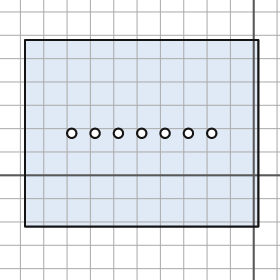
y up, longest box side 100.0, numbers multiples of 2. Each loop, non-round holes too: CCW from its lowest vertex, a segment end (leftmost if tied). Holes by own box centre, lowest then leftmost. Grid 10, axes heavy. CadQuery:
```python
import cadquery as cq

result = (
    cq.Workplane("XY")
    .moveTo(-98.0, -22.0)
    .lineTo(2.0, -22.0)
    .lineTo(2.0, 58.0)
    .lineTo(-98.0, 58.0)
    .close()
    .moveTo(-78.0, 18.0)
    .circle(2.0)
    .moveTo(-68.0, 18.0)
    .circle(2.0)
    .moveTo(-58.0, 18.0)
    .circle(2.0)
    .moveTo(-48.0, 18.0)
    .circle(2.0)
    .moveTo(-38.0, 18.0)
    .circle(2.0)
    .moveTo(-28.0, 18.0)
    .circle(2.0)
    .moveTo(-18.0, 18.0)
    .circle(2.0)
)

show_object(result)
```